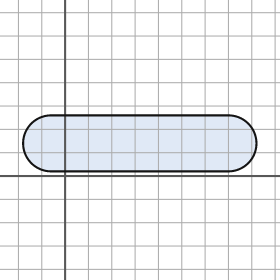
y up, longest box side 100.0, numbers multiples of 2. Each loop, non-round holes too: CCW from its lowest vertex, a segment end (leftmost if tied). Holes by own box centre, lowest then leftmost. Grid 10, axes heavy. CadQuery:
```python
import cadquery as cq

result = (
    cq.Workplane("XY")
    .moveTo(-6.0, 2.0)
    .lineTo(70.0, 2.0)
    .threePointArc((82.0, 14.0), (70.0, 26.0))
    .lineTo(-6.0, 26.0)
    .threePointArc((-18.0, 14.0), (-6.0, 2.0))
    .close()
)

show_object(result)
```